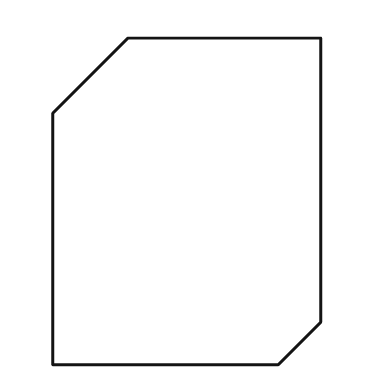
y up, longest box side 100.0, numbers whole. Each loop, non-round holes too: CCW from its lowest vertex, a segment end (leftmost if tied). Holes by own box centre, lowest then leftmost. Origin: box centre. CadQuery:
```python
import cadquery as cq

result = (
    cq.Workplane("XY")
    .moveTo(-41.0, -50.0)
    .lineTo(28.0, -50.0)
    .lineTo(41.0, -37.0)
    .lineTo(41.0, 50.0)
    .lineTo(-18.0, 50.0)
    .lineTo(-41.0, 27.0)
    .close()
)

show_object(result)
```